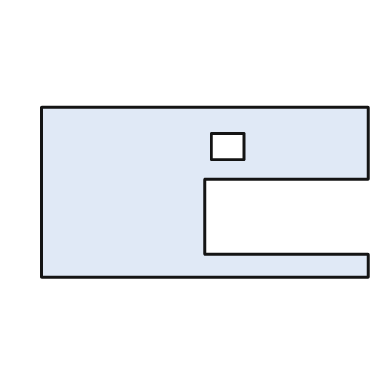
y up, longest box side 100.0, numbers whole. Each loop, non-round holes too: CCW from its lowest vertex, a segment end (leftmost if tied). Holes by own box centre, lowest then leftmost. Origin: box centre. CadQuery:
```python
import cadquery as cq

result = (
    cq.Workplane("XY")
    .moveTo(-50.0, -26.0)
    .lineTo(50.0, -26.0)
    .lineTo(50.0, -19.0)
    .lineTo(0.0, -19.0)
    .lineTo(0.0, 4.0)
    .lineTo(50.0, 4.0)
    .lineTo(50.0, 26.0)
    .lineTo(-50.0, 26.0)
    .close()
    .moveTo(2.0, 10.0)
    .lineTo(12.0, 10.0)
    .lineTo(12.0, 18.0)
    .lineTo(2.0, 18.0)
    .close()
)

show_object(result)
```